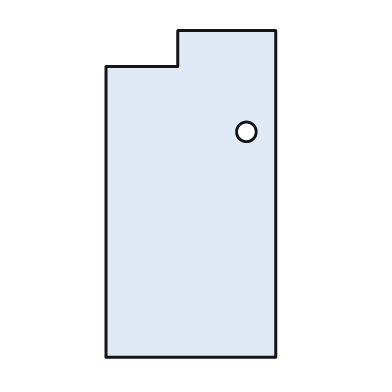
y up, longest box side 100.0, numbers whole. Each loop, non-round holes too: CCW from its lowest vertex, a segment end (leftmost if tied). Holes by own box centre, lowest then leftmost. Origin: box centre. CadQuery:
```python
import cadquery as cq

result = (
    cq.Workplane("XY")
    .moveTo(-26.0, -50.0)
    .lineTo(26.0, -50.0)
    .lineTo(26.0, 50.0)
    .lineTo(-4.0, 50.0)
    .lineTo(-4.0, 39.0)
    .lineTo(-26.0, 39.0)
    .close()
    .moveTo(17.0, 19.0)
    .circle(3.0)
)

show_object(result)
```